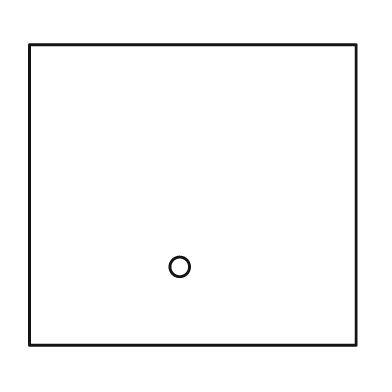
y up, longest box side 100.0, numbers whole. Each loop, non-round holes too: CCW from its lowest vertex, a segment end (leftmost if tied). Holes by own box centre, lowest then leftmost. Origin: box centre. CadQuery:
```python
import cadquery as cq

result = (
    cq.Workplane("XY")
    .moveTo(-50.0, -46.0)
    .lineTo(50.0, -46.0)
    .lineTo(50.0, 46.0)
    .lineTo(-50.0, 46.0)
    .close()
    .moveTo(-4.0, -22.0)
    .circle(3.0)
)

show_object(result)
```